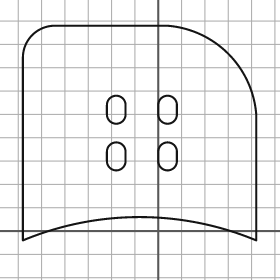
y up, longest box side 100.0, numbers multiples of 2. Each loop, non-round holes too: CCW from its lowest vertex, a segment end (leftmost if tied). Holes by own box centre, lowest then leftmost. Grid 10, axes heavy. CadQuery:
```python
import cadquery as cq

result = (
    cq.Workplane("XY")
    .moveTo(-58.0, -4.0)
    .threePointArc((-8.0, 6.0), (42.0, -4.0))
    .lineTo(42.0, 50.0)
    .threePointArc((30.0, 76.0), (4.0, 88.0))
    .lineTo(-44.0, 88.0)
    .threePointArc((-54.0, 84.0), (-58.0, 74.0))
    .close()
    .moveTo(-22.0, 30.0)
    .threePointArc((-18.0, 26.0), (-14.0, 30.0))
    .lineTo(-14.0, 34.0)
    .threePointArc((-18.0, 38.0), (-22.0, 34.0))
    .close()
    .moveTo(0.0, 30.0)
    .threePointArc((4.0, 26.0), (8.0, 30.0))
    .lineTo(8.0, 34.0)
    .threePointArc((4.0, 38.0), (0.0, 34.0))
    .close()
    .moveTo(-22.0, 50.0)
    .threePointArc((-18.0, 46.0), (-14.0, 50.0))
    .lineTo(-14.0, 54.0)
    .threePointArc((-18.0, 58.0), (-22.0, 54.0))
    .close()
    .moveTo(0.0, 50.0)
    .threePointArc((4.0, 46.0), (8.0, 50.0))
    .lineTo(8.0, 54.0)
    .threePointArc((4.0, 58.0), (0.0, 54.0))
    .close()
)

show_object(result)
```